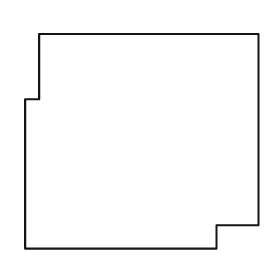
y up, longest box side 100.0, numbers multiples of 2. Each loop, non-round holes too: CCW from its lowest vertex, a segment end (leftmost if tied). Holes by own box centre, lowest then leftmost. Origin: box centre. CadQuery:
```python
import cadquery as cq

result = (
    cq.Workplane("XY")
    .moveTo(-50.0, -46.0)
    .lineTo(32.0, -46.0)
    .lineTo(32.0, -36.0)
    .lineTo(50.0, -36.0)
    .lineTo(50.0, 46.0)
    .lineTo(-44.0, 46.0)
    .lineTo(-44.0, 18.0)
    .lineTo(-50.0, 18.0)
    .close()
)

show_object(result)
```